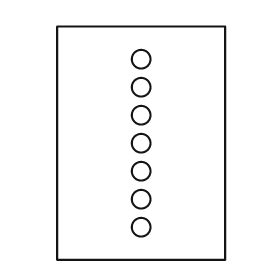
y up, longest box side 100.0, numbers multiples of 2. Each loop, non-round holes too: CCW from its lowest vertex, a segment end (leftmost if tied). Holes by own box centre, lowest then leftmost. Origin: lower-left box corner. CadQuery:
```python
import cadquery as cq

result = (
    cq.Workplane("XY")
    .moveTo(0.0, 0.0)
    .lineTo(72.0, 0.0)
    .lineTo(72.0, 100.0)
    .lineTo(0.0, 100.0)
    .close()
    .moveTo(36.0, 14.0)
    .circle(4.0)
    .moveTo(36.0, 26.0)
    .circle(4.0)
    .moveTo(36.0, 38.0)
    .circle(4.0)
    .moveTo(36.0, 50.0)
    .circle(4.0)
    .moveTo(36.0, 62.0)
    .circle(4.0)
    .moveTo(36.0, 74.0)
    .circle(4.0)
    .moveTo(36.0, 86.0)
    .circle(4.0)
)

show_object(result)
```